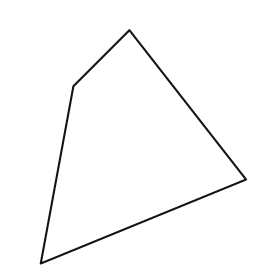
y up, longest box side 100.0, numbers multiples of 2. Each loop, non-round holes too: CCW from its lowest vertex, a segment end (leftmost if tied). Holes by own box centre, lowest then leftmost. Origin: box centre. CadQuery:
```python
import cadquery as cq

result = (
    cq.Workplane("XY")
    .moveTo(-44.0, -50.0)
    .lineTo(44.0, -14.0)
    .lineTo(-6.0, 50.0)
    .lineTo(-30.0, 26.0)
    .close()
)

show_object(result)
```